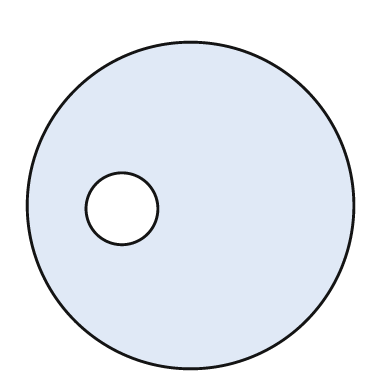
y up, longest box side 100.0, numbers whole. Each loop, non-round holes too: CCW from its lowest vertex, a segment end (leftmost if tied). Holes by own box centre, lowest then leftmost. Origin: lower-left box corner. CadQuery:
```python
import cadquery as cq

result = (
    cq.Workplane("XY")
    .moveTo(50.0, 50.0)
    .circle(50.0)
    .moveTo(29.0, 49.0)
    .circle(11.0)
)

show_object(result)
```